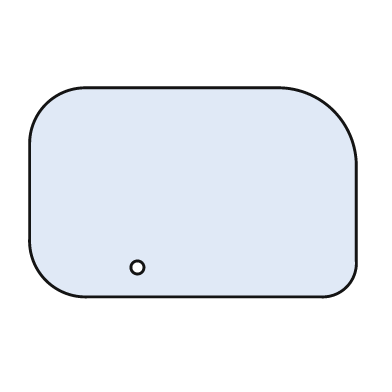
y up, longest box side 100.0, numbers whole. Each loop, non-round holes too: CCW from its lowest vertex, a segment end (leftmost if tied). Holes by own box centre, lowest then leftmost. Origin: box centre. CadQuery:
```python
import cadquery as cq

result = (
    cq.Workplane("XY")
    .moveTo(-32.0, -32.0)
    .lineTo(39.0, -32.0)
    .threePointArc((47.0, -29.0), (50.0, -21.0))
    .lineTo(50.0, 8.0)
    .threePointArc((43.0, 25.0), (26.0, 32.0))
    .lineTo(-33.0, 32.0)
    .threePointArc((-45.0, 27.0), (-50.0, 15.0))
    .lineTo(-50.0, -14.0)
    .threePointArc((-45.0, -27.0), (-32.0, -32.0))
    .close()
    .moveTo(-17.0, -23.0)
    .circle(2.0)
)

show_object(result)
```